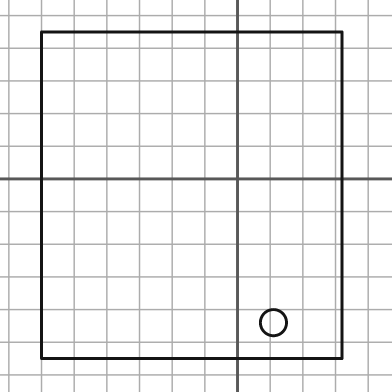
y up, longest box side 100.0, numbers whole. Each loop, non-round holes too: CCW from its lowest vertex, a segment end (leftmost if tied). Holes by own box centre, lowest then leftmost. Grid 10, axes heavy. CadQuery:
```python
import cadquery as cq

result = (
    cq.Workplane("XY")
    .moveTo(-60.0, -55.0)
    .lineTo(32.0, -55.0)
    .lineTo(32.0, 45.0)
    .lineTo(-60.0, 45.0)
    .close()
    .moveTo(11.0, -44.0)
    .circle(4.0)
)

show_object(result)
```